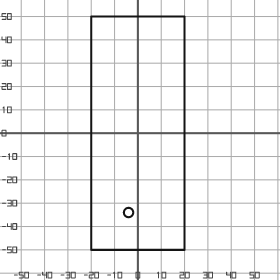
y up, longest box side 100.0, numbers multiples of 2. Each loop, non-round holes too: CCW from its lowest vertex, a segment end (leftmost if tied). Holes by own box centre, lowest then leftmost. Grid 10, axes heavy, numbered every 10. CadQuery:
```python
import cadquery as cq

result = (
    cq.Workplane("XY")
    .moveTo(-20.0, -50.0)
    .lineTo(20.0, -50.0)
    .lineTo(20.0, 50.0)
    .lineTo(-20.0, 50.0)
    .close()
    .moveTo(-4.0, -34.0)
    .circle(2.0)
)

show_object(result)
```